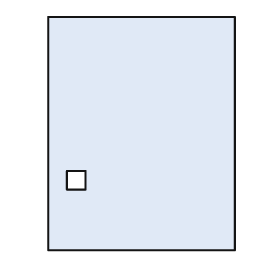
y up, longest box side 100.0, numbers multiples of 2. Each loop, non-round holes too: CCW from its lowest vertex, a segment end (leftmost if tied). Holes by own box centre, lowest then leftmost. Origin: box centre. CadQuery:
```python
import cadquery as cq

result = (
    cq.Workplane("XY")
    .moveTo(-40.0, -50.0)
    .lineTo(40.0, -50.0)
    .lineTo(40.0, 50.0)
    .lineTo(-40.0, 50.0)
    .close()
    .moveTo(-32.0, -24.0)
    .lineTo(-24.0, -24.0)
    .lineTo(-24.0, -16.0)
    .lineTo(-32.0, -16.0)
    .close()
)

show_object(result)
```